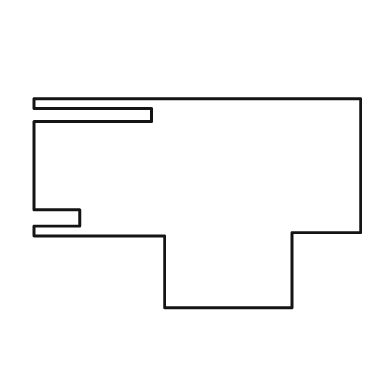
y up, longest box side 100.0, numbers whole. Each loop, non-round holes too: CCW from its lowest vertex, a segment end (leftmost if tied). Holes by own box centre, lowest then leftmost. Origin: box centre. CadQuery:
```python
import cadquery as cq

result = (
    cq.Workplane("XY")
    .moveTo(-10.0, -32.0)
    .lineTo(29.0, -32.0)
    .lineTo(29.0, -9.0)
    .lineTo(50.0, -9.0)
    .lineTo(50.0, 32.0)
    .lineTo(-50.0, 32.0)
    .lineTo(-50.0, 29.0)
    .lineTo(-14.0, 29.0)
    .lineTo(-14.0, 25.0)
    .lineTo(-50.0, 25.0)
    .lineTo(-50.0, -2.0)
    .lineTo(-36.0, -2.0)
    .lineTo(-36.0, -7.0)
    .lineTo(-50.0, -7.0)
    .lineTo(-50.0, -10.0)
    .lineTo(-10.0, -10.0)
    .close()
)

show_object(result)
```